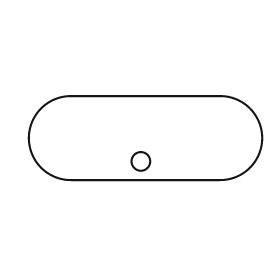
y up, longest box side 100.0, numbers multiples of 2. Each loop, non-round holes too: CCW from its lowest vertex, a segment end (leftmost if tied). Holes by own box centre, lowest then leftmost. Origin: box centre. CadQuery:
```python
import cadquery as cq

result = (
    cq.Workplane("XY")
    .moveTo(-32.0, -18.0)
    .lineTo(32.0, -18.0)
    .threePointArc((50.0, 0.0), (32.0, 18.0))
    .lineTo(-32.0, 18.0)
    .threePointArc((-50.0, 0.0), (-32.0, -18.0))
    .close()
    .moveTo(-2.0, -10.0)
    .circle(4.0)
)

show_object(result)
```